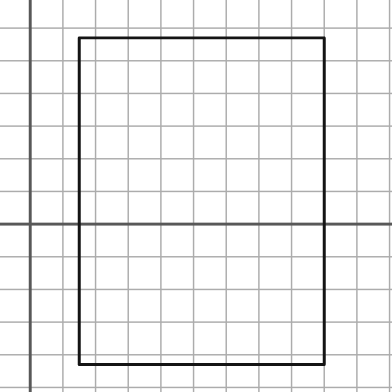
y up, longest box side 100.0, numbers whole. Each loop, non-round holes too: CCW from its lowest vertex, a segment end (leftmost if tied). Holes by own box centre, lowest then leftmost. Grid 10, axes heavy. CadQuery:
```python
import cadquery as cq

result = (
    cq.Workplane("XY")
    .moveTo(15.0, -43.0)
    .lineTo(90.0, -43.0)
    .lineTo(90.0, 57.0)
    .lineTo(15.0, 57.0)
    .close()
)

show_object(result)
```